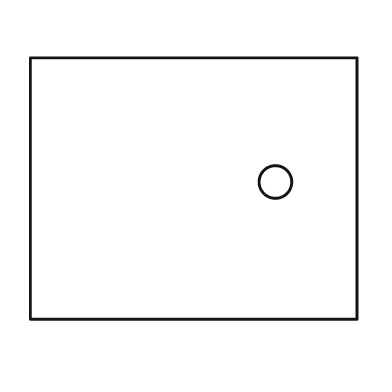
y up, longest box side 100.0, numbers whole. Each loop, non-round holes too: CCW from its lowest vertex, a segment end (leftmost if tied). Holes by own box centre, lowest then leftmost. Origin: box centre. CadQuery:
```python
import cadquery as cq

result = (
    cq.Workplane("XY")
    .moveTo(-50.0, -40.0)
    .lineTo(50.0, -40.0)
    .lineTo(50.0, 40.0)
    .lineTo(-50.0, 40.0)
    .close()
    .moveTo(25.0, 2.0)
    .circle(5.0)
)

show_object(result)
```